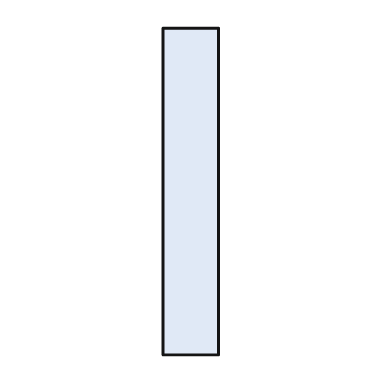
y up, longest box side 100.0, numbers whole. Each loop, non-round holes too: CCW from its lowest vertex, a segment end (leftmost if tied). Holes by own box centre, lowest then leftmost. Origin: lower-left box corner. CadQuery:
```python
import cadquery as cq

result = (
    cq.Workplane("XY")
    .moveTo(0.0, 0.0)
    .lineTo(17.0, 0.0)
    .lineTo(17.0, 100.0)
    .lineTo(0.0, 100.0)
    .close()
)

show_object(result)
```